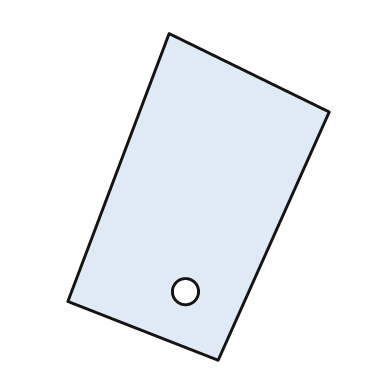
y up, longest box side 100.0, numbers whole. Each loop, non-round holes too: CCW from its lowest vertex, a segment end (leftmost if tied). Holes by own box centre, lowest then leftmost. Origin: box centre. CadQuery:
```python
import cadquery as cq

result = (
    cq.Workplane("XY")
    .moveTo(6.0, -50.0)
    .lineTo(40.0, 26.0)
    .lineTo(-9.0, 50.0)
    .lineTo(-40.0, -32.0)
    .close()
    .moveTo(-4.0, -29.0)
    .circle(4.0)
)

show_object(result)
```